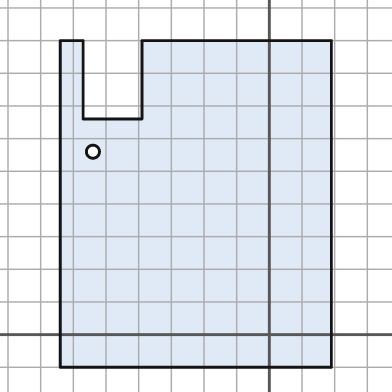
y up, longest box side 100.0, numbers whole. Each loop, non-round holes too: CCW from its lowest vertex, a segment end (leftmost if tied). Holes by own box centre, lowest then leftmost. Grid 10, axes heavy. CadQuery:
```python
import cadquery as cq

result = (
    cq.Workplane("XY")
    .moveTo(-64.0, -10.0)
    .lineTo(19.0, -10.0)
    .lineTo(19.0, 90.0)
    .lineTo(-39.0, 90.0)
    .lineTo(-39.0, 66.0)
    .lineTo(-57.0, 66.0)
    .lineTo(-57.0, 90.0)
    .lineTo(-64.0, 90.0)
    .close()
    .moveTo(-54.0, 56.0)
    .circle(2.0)
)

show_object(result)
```